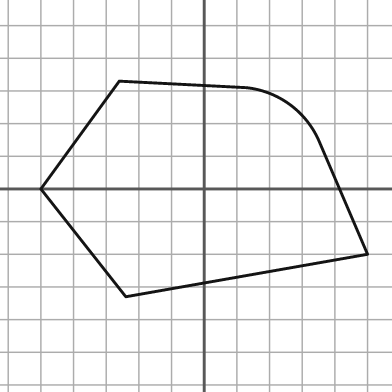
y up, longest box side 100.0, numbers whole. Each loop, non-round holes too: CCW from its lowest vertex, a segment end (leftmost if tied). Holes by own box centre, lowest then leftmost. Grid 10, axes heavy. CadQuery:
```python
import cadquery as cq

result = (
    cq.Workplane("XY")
    .moveTo(-24.0, -33.0)
    .lineTo(50.0, -20.0)
    .lineTo(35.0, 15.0)
    .threePointArc((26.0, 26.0), (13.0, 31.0))
    .lineTo(-26.0, 33.0)
    .lineTo(-50.0, 0.0)
    .close()
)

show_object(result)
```